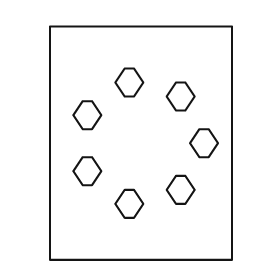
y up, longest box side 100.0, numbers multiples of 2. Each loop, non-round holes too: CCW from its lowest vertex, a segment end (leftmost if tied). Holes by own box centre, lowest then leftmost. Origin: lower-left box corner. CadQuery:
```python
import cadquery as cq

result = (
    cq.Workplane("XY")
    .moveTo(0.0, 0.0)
    .lineTo(78.0, 0.0)
    .lineTo(78.0, 100.0)
    .lineTo(0.0, 100.0)
    .close()
    .moveTo(32.0, 18.0)
    .lineTo(36.0, 18.0)
    .lineTo(40.0, 24.0)
    .lineTo(36.0, 30.0)
    .lineTo(32.0, 30.0)
    .lineTo(28.0, 24.0)
    .close()
    .moveTo(54.0, 24.0)
    .lineTo(58.0, 24.0)
    .lineTo(62.0, 30.0)
    .lineTo(58.0, 36.0)
    .lineTo(54.0, 36.0)
    .lineTo(50.0, 30.0)
    .close()
    .moveTo(14.0, 32.0)
    .lineTo(18.0, 32.0)
    .lineTo(22.0, 38.0)
    .lineTo(18.0, 44.0)
    .lineTo(14.0, 44.0)
    .lineTo(10.0, 38.0)
    .close()
    .moveTo(64.0, 44.0)
    .lineTo(68.0, 44.0)
    .lineTo(72.0, 50.0)
    .lineTo(68.0, 56.0)
    .lineTo(64.0, 56.0)
    .lineTo(60.0, 50.0)
    .close()
    .moveTo(14.0, 56.0)
    .lineTo(18.0, 56.0)
    .lineTo(22.0, 62.0)
    .lineTo(18.0, 68.0)
    .lineTo(14.0, 68.0)
    .lineTo(10.0, 62.0)
    .close()
    .moveTo(54.0, 64.0)
    .lineTo(58.0, 64.0)
    .lineTo(62.0, 70.0)
    .lineTo(58.0, 76.0)
    .lineTo(54.0, 76.0)
    .lineTo(50.0, 70.0)
    .close()
    .moveTo(32.0, 70.0)
    .lineTo(36.0, 70.0)
    .lineTo(40.0, 76.0)
    .lineTo(36.0, 82.0)
    .lineTo(32.0, 82.0)
    .lineTo(28.0, 76.0)
    .close()
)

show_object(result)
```